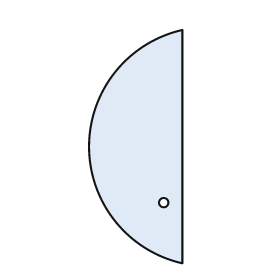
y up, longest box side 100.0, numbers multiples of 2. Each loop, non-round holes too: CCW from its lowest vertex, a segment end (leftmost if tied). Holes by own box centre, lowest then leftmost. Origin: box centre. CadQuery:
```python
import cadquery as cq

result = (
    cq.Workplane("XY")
    .moveTo(20.0, -50.0)
    .lineTo(20.0, 50.0)
    .threePointArc((-20.0, 0.0), (20.0, -50.0))
    .close()
    .moveTo(12.0, -24.0)
    .circle(2.0)
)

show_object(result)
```